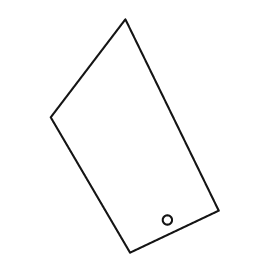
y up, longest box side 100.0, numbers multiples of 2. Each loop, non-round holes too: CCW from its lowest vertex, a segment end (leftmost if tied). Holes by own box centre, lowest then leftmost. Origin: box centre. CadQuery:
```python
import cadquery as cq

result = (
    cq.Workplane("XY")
    .moveTo(-2.0, -50.0)
    .lineTo(36.0, -32.0)
    .lineTo(-4.0, 50.0)
    .lineTo(-36.0, 8.0)
    .close()
    .moveTo(14.0, -36.0)
    .circle(2.0)
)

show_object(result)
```